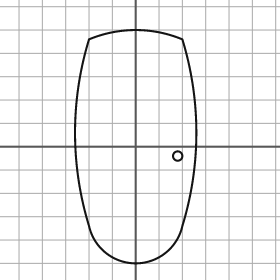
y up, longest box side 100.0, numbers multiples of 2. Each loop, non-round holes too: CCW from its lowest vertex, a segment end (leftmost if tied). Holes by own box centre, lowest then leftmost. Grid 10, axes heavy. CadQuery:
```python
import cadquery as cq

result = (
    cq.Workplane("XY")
    .moveTo(-20.0, -34.0)
    .threePointArc((0.0, -50.0), (20.0, -34.0))
    .threePointArc((26.0, 6.0), (20.0, 46.0))
    .threePointArc((0.0, 50.0), (-20.0, 46.0))
    .threePointArc((-26.0, 6.0), (-20.0, -34.0))
    .close()
    .moveTo(18.0, -4.0)
    .circle(2.0)
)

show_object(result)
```